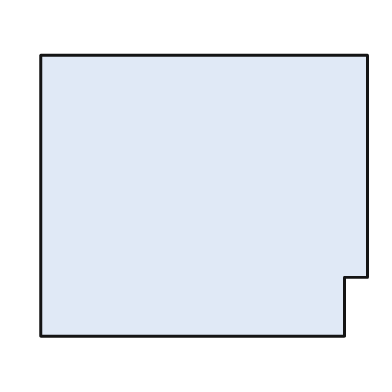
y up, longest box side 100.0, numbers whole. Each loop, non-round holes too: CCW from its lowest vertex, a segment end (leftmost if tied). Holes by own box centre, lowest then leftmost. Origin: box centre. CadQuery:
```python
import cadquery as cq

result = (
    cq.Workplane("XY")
    .moveTo(-50.0, -43.0)
    .lineTo(43.0, -43.0)
    .lineTo(43.0, -25.0)
    .lineTo(50.0, -25.0)
    .lineTo(50.0, 43.0)
    .lineTo(-50.0, 43.0)
    .close()
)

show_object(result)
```